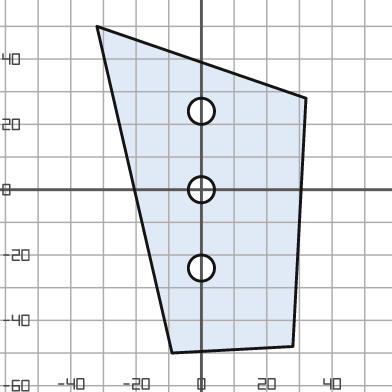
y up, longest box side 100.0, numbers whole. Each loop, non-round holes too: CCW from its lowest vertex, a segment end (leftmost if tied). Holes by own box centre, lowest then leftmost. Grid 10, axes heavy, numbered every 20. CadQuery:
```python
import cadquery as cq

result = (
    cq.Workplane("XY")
    .moveTo(-9.0, -50.0)
    .lineTo(28.0, -48.0)
    .lineTo(32.0, 28.0)
    .lineTo(-32.0, 50.0)
    .close()
    .moveTo(0.0, -24.0)
    .circle(4.0)
    .moveTo(0.0, 0.0)
    .circle(4.0)
    .moveTo(0.0, 24.0)
    .circle(4.0)
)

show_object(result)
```